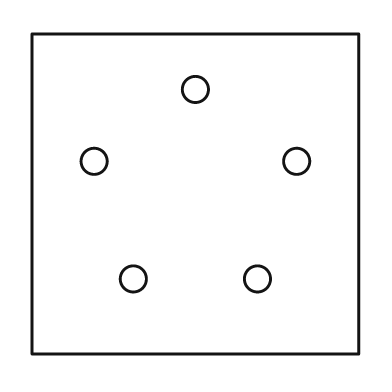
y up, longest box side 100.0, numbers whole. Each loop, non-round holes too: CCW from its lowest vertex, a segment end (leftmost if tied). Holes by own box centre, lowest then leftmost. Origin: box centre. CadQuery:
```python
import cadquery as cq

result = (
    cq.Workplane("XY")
    .moveTo(-50.0, -49.0)
    .lineTo(50.0, -49.0)
    .lineTo(50.0, 49.0)
    .lineTo(-50.0, 49.0)
    .close()
    .moveTo(-19.0, -26.0)
    .circle(4.0)
    .moveTo(19.0, -26.0)
    .circle(4.0)
    .moveTo(-31.0, 10.0)
    .circle(4.0)
    .moveTo(31.0, 10.0)
    .circle(4.0)
    .moveTo(0.0, 32.0)
    .circle(4.0)
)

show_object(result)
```